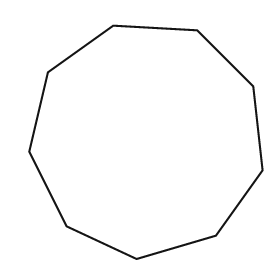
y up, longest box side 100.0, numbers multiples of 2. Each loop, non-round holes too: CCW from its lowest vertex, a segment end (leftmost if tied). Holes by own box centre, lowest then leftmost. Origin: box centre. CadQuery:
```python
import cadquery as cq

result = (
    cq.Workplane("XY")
    .moveTo(-4.0, -50.0)
    .lineTo(30.0, -40.0)
    .lineTo(50.0, -12.0)
    .lineTo(46.0, 24.0)
    .lineTo(22.0, 48.0)
    .lineTo(-14.0, 50.0)
    .lineTo(-42.0, 30.0)
    .lineTo(-50.0, -4.0)
    .lineTo(-34.0, -36.0)
    .close()
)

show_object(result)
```